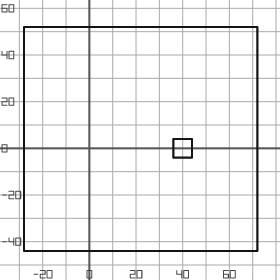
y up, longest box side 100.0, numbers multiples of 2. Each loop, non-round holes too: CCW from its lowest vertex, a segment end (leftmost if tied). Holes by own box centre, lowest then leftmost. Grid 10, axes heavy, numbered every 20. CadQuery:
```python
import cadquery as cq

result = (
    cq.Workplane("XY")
    .moveTo(-28.0, -44.0)
    .lineTo(72.0, -44.0)
    .lineTo(72.0, 52.0)
    .lineTo(-28.0, 52.0)
    .close()
    .moveTo(36.0, -4.0)
    .lineTo(44.0, -4.0)
    .lineTo(44.0, 4.0)
    .lineTo(36.0, 4.0)
    .close()
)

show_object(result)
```